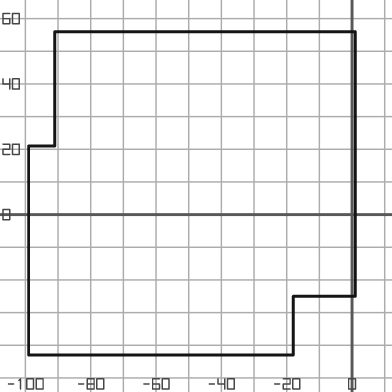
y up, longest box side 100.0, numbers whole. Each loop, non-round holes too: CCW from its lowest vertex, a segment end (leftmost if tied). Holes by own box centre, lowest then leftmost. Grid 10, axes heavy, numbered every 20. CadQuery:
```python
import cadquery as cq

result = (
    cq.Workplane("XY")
    .moveTo(-99.0, -43.0)
    .lineTo(-18.0, -43.0)
    .lineTo(-18.0, -25.0)
    .lineTo(1.0, -25.0)
    .lineTo(1.0, 56.0)
    .lineTo(-91.0, 56.0)
    .lineTo(-91.0, 21.0)
    .lineTo(-99.0, 21.0)
    .close()
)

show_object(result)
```